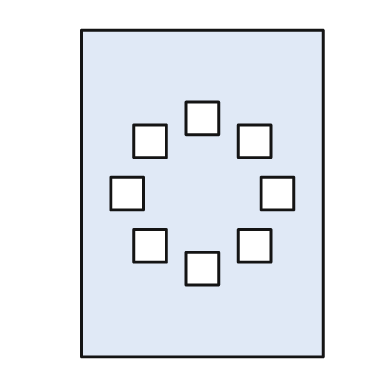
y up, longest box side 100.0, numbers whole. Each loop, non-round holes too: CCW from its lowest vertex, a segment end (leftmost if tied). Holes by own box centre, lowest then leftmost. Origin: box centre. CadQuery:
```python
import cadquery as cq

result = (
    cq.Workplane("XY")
    .moveTo(-37.0, -50.0)
    .lineTo(37.0, -50.0)
    .lineTo(37.0, 50.0)
    .lineTo(-37.0, 50.0)
    .close()
    .moveTo(-5.0, -28.0)
    .lineTo(5.0, -28.0)
    .lineTo(5.0, -18.0)
    .lineTo(-5.0, -18.0)
    .close()
    .moveTo(-21.0, -21.0)
    .lineTo(-11.0, -21.0)
    .lineTo(-11.0, -11.0)
    .lineTo(-21.0, -11.0)
    .close()
    .moveTo(11.0, -21.0)
    .lineTo(21.0, -21.0)
    .lineTo(21.0, -11.0)
    .lineTo(11.0, -11.0)
    .close()
    .moveTo(-28.0, -5.0)
    .lineTo(-18.0, -5.0)
    .lineTo(-18.0, 5.0)
    .lineTo(-28.0, 5.0)
    .close()
    .moveTo(18.0, -5.0)
    .lineTo(28.0, -5.0)
    .lineTo(28.0, 5.0)
    .lineTo(18.0, 5.0)
    .close()
    .moveTo(-21.0, 11.0)
    .lineTo(-11.0, 11.0)
    .lineTo(-11.0, 21.0)
    .lineTo(-21.0, 21.0)
    .close()
    .moveTo(11.0, 11.0)
    .lineTo(21.0, 11.0)
    .lineTo(21.0, 21.0)
    .lineTo(11.0, 21.0)
    .close()
    .moveTo(-5.0, 18.0)
    .lineTo(5.0, 18.0)
    .lineTo(5.0, 28.0)
    .lineTo(-5.0, 28.0)
    .close()
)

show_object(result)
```